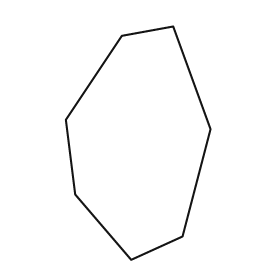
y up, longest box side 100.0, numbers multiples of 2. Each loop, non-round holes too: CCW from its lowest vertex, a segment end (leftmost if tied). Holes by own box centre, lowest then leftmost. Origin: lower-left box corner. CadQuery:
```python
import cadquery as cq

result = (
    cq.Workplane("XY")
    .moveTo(28.0, 0.0)
    .lineTo(50.0, 10.0)
    .lineTo(62.0, 56.0)
    .lineTo(46.0, 100.0)
    .lineTo(24.0, 96.0)
    .lineTo(0.0, 60.0)
    .lineTo(4.0, 28.0)
    .close()
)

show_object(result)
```